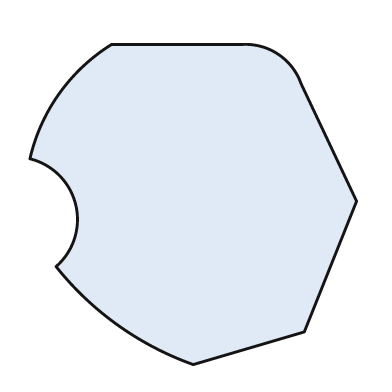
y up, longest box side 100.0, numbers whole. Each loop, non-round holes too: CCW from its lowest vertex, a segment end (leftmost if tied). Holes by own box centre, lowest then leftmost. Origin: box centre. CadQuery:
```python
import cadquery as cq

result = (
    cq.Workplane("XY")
    .moveTo(0.0, -49.0)
    .lineTo(34.0, -39.0)
    .lineTo(50.0, 1.0)
    .lineTo(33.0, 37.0)
    .threePointArc((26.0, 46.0), (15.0, 49.0))
    .lineTo(-25.0, 49.0)
    .threePointArc((-41.0, 34.0), (-50.0, 14.0))
    .threePointArc((-36.0, 0.0), (-42.0, -19.0))
    .threePointArc((-23.0, -37.0), (0.0, -49.0))
    .close()
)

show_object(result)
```